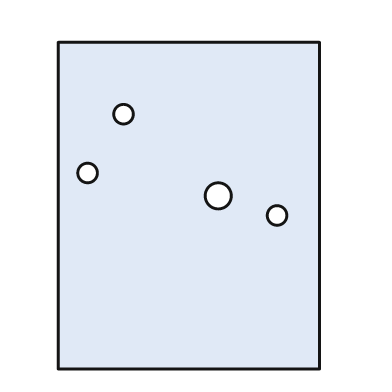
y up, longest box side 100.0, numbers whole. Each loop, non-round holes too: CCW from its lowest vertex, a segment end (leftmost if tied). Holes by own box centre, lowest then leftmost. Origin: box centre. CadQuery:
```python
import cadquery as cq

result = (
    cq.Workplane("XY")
    .moveTo(-40.0, -50.0)
    .lineTo(40.0, -50.0)
    .lineTo(40.0, 50.0)
    .lineTo(-40.0, 50.0)
    .close()
    .moveTo(27.0, -3.0)
    .circle(3.0)
    .moveTo(9.0, 3.0)
    .circle(4.0)
    .moveTo(-31.0, 10.0)
    .circle(3.0)
    .moveTo(-20.0, 28.0)
    .circle(3.0)
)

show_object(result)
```